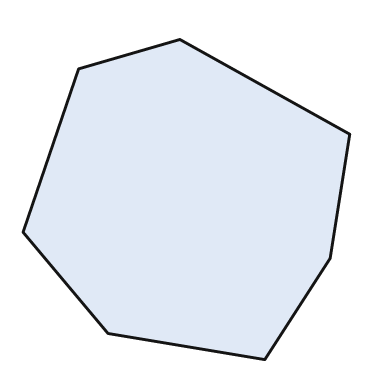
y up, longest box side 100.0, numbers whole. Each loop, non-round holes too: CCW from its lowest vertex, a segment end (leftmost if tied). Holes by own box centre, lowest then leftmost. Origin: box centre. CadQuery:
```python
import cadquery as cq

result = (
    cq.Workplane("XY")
    .moveTo(24.0, -49.0)
    .lineTo(44.0, -18.0)
    .lineTo(50.0, 20.0)
    .lineTo(-2.0, 49.0)
    .lineTo(-33.0, 40.0)
    .lineTo(-50.0, -10.0)
    .lineTo(-24.0, -41.0)
    .close()
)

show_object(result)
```